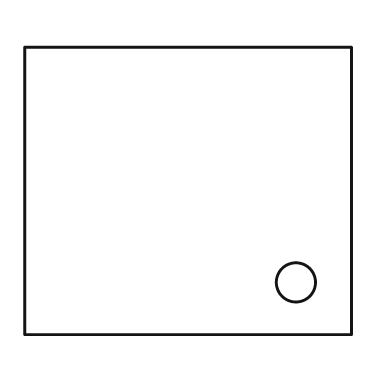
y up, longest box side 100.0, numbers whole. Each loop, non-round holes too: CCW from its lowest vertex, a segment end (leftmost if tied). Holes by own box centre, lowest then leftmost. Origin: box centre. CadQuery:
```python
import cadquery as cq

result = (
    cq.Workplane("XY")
    .moveTo(-50.0, -44.0)
    .lineTo(50.0, -44.0)
    .lineTo(50.0, 44.0)
    .lineTo(-50.0, 44.0)
    .close()
    .moveTo(33.0, -28.0)
    .circle(6.0)
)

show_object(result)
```